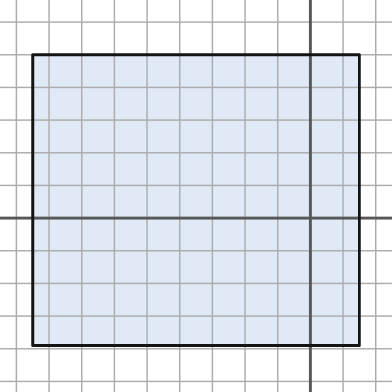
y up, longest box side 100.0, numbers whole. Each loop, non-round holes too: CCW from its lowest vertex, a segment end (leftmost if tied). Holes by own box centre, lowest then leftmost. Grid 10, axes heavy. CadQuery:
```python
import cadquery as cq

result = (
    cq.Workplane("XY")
    .moveTo(-85.0, -39.0)
    .lineTo(15.0, -39.0)
    .lineTo(15.0, 50.0)
    .lineTo(-85.0, 50.0)
    .close()
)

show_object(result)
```